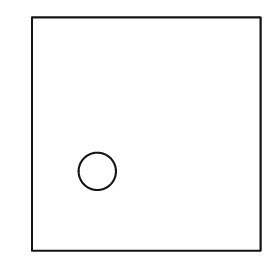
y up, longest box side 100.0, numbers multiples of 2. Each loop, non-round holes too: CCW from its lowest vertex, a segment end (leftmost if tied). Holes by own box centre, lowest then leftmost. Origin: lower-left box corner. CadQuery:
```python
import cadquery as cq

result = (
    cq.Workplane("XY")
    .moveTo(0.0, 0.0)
    .lineTo(98.0, 0.0)
    .lineTo(98.0, 100.0)
    .lineTo(0.0, 100.0)
    .close()
    .moveTo(28.0, 34.0)
    .circle(8.0)
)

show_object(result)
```